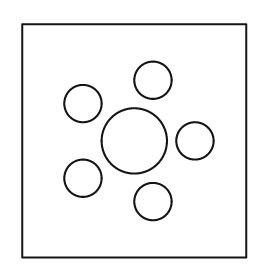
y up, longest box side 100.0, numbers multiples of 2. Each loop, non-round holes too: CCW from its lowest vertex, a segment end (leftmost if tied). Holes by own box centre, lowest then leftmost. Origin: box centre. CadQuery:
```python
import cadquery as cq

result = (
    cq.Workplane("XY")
    .moveTo(-48.0, -50.0)
    .lineTo(48.0, -50.0)
    .lineTo(48.0, 50.0)
    .lineTo(-48.0, 50.0)
    .close()
    .moveTo(8.0, -26.0)
    .circle(8.0)
    .moveTo(-22.0, -16.0)
    .circle(8.0)
    .moveTo(0.0, 0.0)
    .circle(14.0)
    .moveTo(26.0, 0.0)
    .circle(8.0)
    .moveTo(-22.0, 16.0)
    .circle(8.0)
    .moveTo(8.0, 26.0)
    .circle(8.0)
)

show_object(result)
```